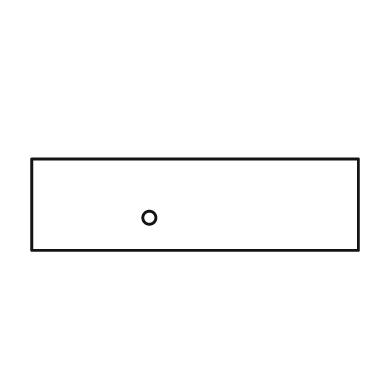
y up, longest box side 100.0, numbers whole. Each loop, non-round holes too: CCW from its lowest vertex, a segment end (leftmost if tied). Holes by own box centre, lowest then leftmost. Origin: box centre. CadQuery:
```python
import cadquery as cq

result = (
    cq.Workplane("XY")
    .moveTo(-50.0, -14.0)
    .lineTo(50.0, -14.0)
    .lineTo(50.0, 14.0)
    .lineTo(-50.0, 14.0)
    .close()
    .moveTo(-14.0, -4.0)
    .circle(2.0)
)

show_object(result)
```